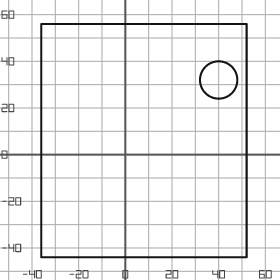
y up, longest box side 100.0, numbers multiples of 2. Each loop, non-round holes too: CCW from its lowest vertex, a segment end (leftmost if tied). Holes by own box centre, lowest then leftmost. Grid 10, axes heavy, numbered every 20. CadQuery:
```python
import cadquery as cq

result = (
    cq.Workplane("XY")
    .moveTo(-36.0, -44.0)
    .lineTo(52.0, -44.0)
    .lineTo(52.0, 56.0)
    .lineTo(-36.0, 56.0)
    .close()
    .moveTo(40.0, 32.0)
    .circle(8.0)
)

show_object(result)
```